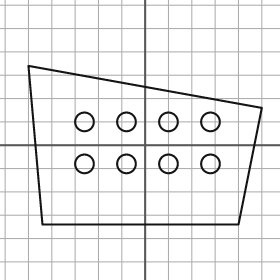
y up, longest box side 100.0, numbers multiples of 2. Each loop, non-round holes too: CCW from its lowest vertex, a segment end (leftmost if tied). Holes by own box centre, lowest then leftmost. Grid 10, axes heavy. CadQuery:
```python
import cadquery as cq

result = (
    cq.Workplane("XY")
    .moveTo(-44.0, -34.0)
    .lineTo(40.0, -34.0)
    .lineTo(50.0, 16.0)
    .lineTo(-50.0, 34.0)
    .close()
    .moveTo(-26.0, -8.0)
    .circle(4.0)
    .moveTo(-8.0, -8.0)
    .circle(4.0)
    .moveTo(10.0, -8.0)
    .circle(4.0)
    .moveTo(28.0, -8.0)
    .circle(4.0)
    .moveTo(-26.0, 10.0)
    .circle(4.0)
    .moveTo(-8.0, 10.0)
    .circle(4.0)
    .moveTo(10.0, 10.0)
    .circle(4.0)
    .moveTo(28.0, 10.0)
    .circle(4.0)
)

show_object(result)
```